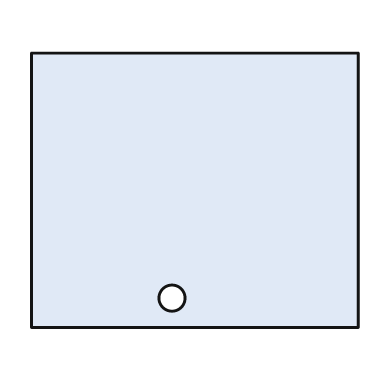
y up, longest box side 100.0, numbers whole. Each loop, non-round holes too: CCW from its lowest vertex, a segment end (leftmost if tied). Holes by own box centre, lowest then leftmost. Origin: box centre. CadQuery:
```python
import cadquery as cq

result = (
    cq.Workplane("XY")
    .moveTo(-50.0, -42.0)
    .lineTo(50.0, -42.0)
    .lineTo(50.0, 42.0)
    .lineTo(-50.0, 42.0)
    .close()
    .moveTo(-7.0, -33.0)
    .circle(4.0)
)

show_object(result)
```